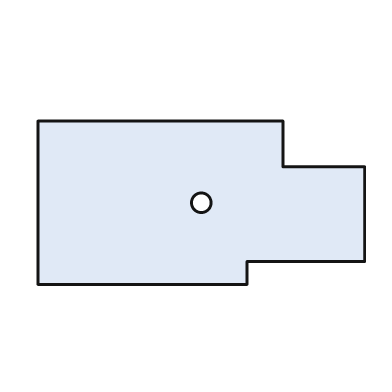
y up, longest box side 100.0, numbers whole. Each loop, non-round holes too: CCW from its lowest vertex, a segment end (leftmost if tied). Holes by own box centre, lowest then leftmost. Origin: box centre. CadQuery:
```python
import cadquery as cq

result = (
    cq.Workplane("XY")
    .moveTo(-50.0, -25.0)
    .lineTo(14.0, -25.0)
    .lineTo(14.0, -18.0)
    .lineTo(50.0, -18.0)
    .lineTo(50.0, 11.0)
    .lineTo(25.0, 11.0)
    .lineTo(25.0, 25.0)
    .lineTo(-50.0, 25.0)
    .close()
    .moveTo(0.0, 0.0)
    .circle(3.0)
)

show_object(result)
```